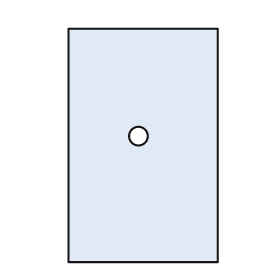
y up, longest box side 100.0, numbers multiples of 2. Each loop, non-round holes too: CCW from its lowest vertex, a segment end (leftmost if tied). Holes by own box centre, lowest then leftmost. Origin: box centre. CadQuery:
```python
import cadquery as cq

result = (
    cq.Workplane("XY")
    .moveTo(-32.0, -50.0)
    .lineTo(32.0, -50.0)
    .lineTo(32.0, 50.0)
    .lineTo(-32.0, 50.0)
    .close()
    .moveTo(-2.0, 4.0)
    .circle(4.0)
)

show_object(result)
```